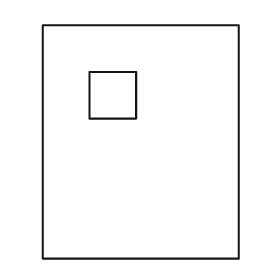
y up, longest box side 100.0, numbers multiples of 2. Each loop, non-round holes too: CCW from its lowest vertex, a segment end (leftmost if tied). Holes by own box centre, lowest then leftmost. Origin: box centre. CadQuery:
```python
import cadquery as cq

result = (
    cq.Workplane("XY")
    .moveTo(-42.0, -50.0)
    .lineTo(42.0, -50.0)
    .lineTo(42.0, 50.0)
    .lineTo(-42.0, 50.0)
    .close()
    .moveTo(-22.0, 10.0)
    .lineTo(-2.0, 10.0)
    .lineTo(-2.0, 30.0)
    .lineTo(-22.0, 30.0)
    .close()
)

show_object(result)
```